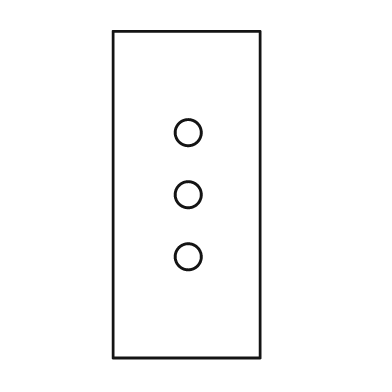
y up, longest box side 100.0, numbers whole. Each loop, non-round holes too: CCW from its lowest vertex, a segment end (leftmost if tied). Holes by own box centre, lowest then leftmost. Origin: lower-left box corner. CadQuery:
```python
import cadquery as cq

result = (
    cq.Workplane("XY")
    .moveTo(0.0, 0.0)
    .lineTo(45.0, 0.0)
    .lineTo(45.0, 100.0)
    .lineTo(0.0, 100.0)
    .close()
    .moveTo(23.0, 31.0)
    .circle(4.0)
    .moveTo(23.0, 50.0)
    .circle(4.0)
    .moveTo(23.0, 69.0)
    .circle(4.0)
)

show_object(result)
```